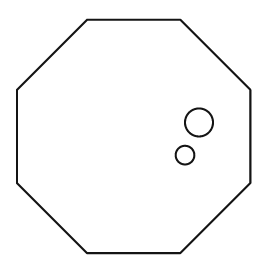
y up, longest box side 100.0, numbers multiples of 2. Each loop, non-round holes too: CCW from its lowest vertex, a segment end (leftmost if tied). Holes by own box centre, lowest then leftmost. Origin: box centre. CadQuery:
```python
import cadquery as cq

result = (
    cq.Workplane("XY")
    .moveTo(-20.0, -50.0)
    .lineTo(20.0, -50.0)
    .lineTo(50.0, -20.0)
    .lineTo(50.0, 20.0)
    .lineTo(20.0, 50.0)
    .lineTo(-20.0, 50.0)
    .lineTo(-50.0, 20.0)
    .lineTo(-50.0, -20.0)
    .close()
    .moveTo(22.0, -8.0)
    .circle(4.0)
    .moveTo(28.0, 6.0)
    .circle(6.0)
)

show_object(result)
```